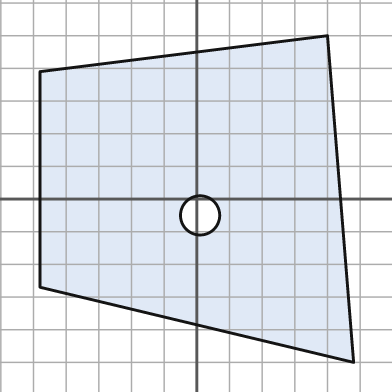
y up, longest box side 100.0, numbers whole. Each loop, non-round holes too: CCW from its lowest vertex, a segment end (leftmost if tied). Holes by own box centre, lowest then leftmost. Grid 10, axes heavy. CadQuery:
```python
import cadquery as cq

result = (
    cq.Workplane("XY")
    .moveTo(48.0, -50.0)
    .lineTo(40.0, 50.0)
    .lineTo(-48.0, 39.0)
    .lineTo(-48.0, -27.0)
    .close()
    .moveTo(1.0, -5.0)
    .circle(6.0)
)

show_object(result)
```